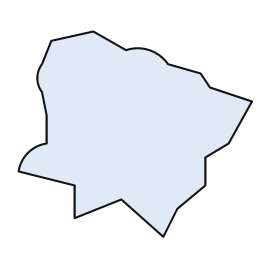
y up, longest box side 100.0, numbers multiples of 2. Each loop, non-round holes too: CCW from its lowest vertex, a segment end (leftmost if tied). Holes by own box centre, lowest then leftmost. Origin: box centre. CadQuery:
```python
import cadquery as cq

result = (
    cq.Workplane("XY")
    .moveTo(12.0, -44.0)
    .lineTo(18.0, -32.0)
    .lineTo(30.0, -22.0)
    .lineTo(30.0, -10.0)
    .lineTo(40.0, -4.0)
    .lineTo(50.0, 14.0)
    .lineTo(32.0, 20.0)
    .lineTo(28.0, 26.0)
    .lineTo(14.0, 30.0)
    .threePointArc((6.0, 36.0), (-4.0, 36.0))
    .lineTo(-18.0, 44.0)
    .lineTo(-36.0, 40.0)
    .lineTo(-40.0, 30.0)
    .threePointArc((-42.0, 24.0), (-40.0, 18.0))
    .lineTo(-38.0, 8.0)
    .lineTo(-38.0, -4.0)
    .threePointArc((-46.0, -8.0), (-50.0, -16.0))
    .lineTo(-26.0, -22.0)
    .lineTo(-26.0, -36.0)
    .lineTo(-6.0, -28.0)
    .close()
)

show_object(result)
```